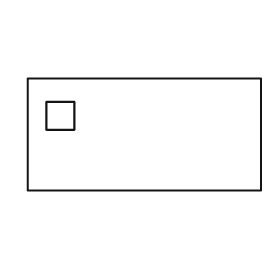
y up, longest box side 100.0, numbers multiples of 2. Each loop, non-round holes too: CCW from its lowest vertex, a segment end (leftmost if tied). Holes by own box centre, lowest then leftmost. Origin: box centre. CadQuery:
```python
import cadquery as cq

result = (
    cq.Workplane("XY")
    .moveTo(-50.0, -24.0)
    .lineTo(50.0, -24.0)
    .lineTo(50.0, 24.0)
    .lineTo(-50.0, 24.0)
    .close()
    .moveTo(-42.0, 2.0)
    .lineTo(-30.0, 2.0)
    .lineTo(-30.0, 14.0)
    .lineTo(-42.0, 14.0)
    .close()
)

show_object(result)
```